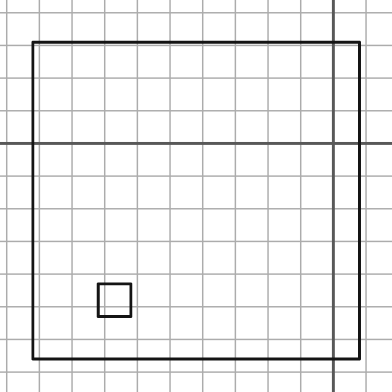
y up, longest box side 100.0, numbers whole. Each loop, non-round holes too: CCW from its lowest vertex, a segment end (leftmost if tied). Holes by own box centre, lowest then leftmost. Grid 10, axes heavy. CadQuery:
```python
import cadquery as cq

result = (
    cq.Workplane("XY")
    .moveTo(-92.0, -66.0)
    .lineTo(8.0, -66.0)
    .lineTo(8.0, 31.0)
    .lineTo(-92.0, 31.0)
    .close()
    .moveTo(-72.0, -53.0)
    .lineTo(-62.0, -53.0)
    .lineTo(-62.0, -43.0)
    .lineTo(-72.0, -43.0)
    .close()
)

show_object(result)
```